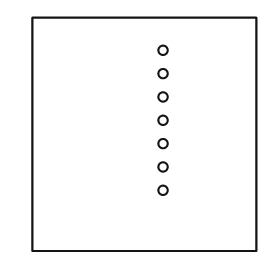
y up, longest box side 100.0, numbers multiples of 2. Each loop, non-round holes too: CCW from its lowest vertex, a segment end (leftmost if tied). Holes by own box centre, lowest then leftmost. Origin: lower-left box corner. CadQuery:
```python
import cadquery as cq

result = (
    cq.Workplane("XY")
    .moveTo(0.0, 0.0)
    .lineTo(96.0, 0.0)
    .lineTo(96.0, 100.0)
    .lineTo(0.0, 100.0)
    .close()
    .moveTo(56.0, 26.0)
    .circle(2.0)
    .moveTo(56.0, 36.0)
    .circle(2.0)
    .moveTo(56.0, 46.0)
    .circle(2.0)
    .moveTo(56.0, 56.0)
    .circle(2.0)
    .moveTo(56.0, 66.0)
    .circle(2.0)
    .moveTo(56.0, 76.0)
    .circle(2.0)
    .moveTo(56.0, 86.0)
    .circle(2.0)
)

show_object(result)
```